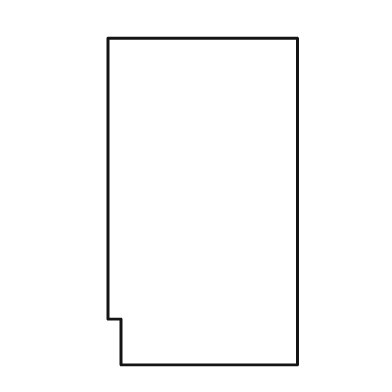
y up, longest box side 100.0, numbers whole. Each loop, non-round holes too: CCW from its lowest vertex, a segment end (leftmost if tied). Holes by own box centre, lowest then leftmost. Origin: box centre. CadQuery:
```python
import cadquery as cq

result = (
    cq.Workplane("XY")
    .moveTo(-25.0, -50.0)
    .lineTo(29.0, -50.0)
    .lineTo(29.0, 50.0)
    .lineTo(-29.0, 50.0)
    .lineTo(-29.0, -36.0)
    .lineTo(-25.0, -36.0)
    .close()
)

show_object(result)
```